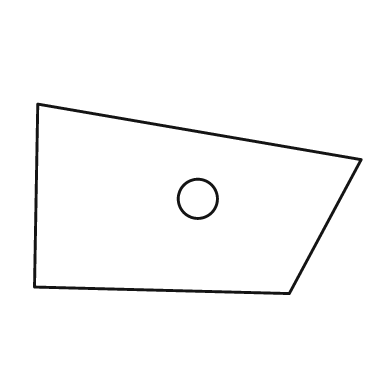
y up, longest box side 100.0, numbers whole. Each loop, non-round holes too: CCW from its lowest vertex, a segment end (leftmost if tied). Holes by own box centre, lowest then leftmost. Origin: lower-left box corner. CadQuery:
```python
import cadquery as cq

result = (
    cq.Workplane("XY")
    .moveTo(78.0, 0.0)
    .lineTo(100.0, 41.0)
    .lineTo(1.0, 58.0)
    .lineTo(0.0, 2.0)
    .close()
    .moveTo(50.0, 29.0)
    .circle(6.0)
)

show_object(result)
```